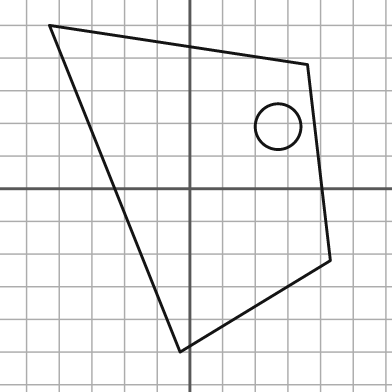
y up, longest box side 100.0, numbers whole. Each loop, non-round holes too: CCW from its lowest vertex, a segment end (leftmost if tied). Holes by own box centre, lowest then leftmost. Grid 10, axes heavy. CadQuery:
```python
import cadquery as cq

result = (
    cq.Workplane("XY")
    .moveTo(-3.0, -50.0)
    .lineTo(43.0, -22.0)
    .lineTo(36.0, 38.0)
    .lineTo(-43.0, 50.0)
    .close()
    .moveTo(27.0, 19.0)
    .circle(7.0)
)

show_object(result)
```